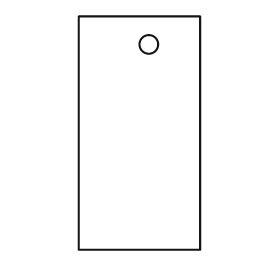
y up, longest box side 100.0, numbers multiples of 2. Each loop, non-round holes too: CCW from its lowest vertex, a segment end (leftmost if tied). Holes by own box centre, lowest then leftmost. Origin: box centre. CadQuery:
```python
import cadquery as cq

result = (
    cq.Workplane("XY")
    .moveTo(-26.0, -50.0)
    .lineTo(26.0, -50.0)
    .lineTo(26.0, 50.0)
    .lineTo(-26.0, 50.0)
    .close()
    .moveTo(4.0, 38.0)
    .circle(4.0)
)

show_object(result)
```